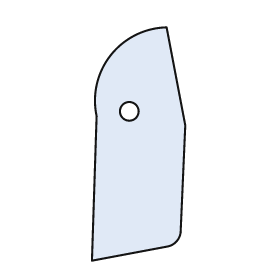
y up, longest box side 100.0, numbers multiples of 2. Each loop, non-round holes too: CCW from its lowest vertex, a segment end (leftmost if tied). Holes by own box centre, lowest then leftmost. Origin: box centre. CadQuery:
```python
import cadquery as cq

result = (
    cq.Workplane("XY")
    .moveTo(-20.0, -50.0)
    .lineTo(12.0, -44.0)
    .threePointArc((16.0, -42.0), (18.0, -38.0))
    .lineTo(20.0, 8.0)
    .lineTo(12.0, 50.0)
    .threePointArc((-12.0, 38.0), (-18.0, 12.0))
    .close()
    .moveTo(-4.0, 14.0)
    .circle(4.0)
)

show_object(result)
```